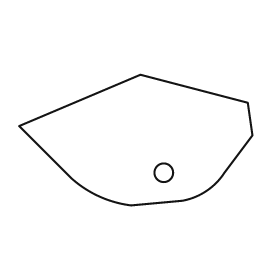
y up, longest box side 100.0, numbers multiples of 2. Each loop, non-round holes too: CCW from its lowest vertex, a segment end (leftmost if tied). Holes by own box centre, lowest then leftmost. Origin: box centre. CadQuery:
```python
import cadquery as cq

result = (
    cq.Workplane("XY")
    .moveTo(-2.0, -28.0)
    .lineTo(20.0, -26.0)
    .threePointArc((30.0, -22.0), (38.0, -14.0))
    .lineTo(50.0, 2.0)
    .lineTo(48.0, 16.0)
    .lineTo(2.0, 28.0)
    .lineTo(-50.0, 6.0)
    .lineTo(-28.0, -16.0)
    .threePointArc((-16.0, -24.0), (-2.0, -28.0))
    .close()
    .moveTo(12.0, -14.0)
    .circle(4.0)
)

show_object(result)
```